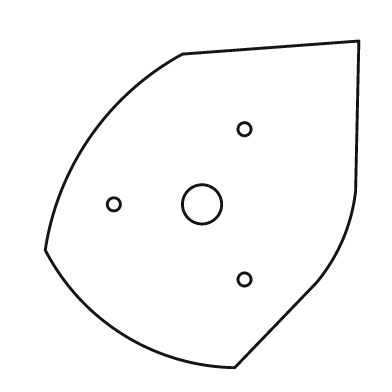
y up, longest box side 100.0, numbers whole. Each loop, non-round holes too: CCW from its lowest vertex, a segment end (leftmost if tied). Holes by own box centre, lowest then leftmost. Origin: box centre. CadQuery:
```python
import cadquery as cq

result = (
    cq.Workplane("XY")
    .moveTo(10.0, -50.0)
    .lineTo(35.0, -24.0)
    .threePointArc((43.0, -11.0), (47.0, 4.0))
    .lineTo(48.0, 50.0)
    .lineTo(-6.0, 46.0)
    .threePointArc((-34.0, 21.0), (-48.0, -14.0))
    .threePointArc((-24.0, -40.0), (10.0, -50.0))
    .close()
    .moveTo(13.0, -23.0)
    .circle(2.0)
    .moveTo(-27.0, 0.0)
    .circle(2.0)
    .moveTo(0.0, 0.0)
    .circle(6.0)
    .moveTo(13.0, 23.0)
    .circle(2.0)
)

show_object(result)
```